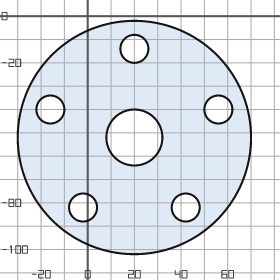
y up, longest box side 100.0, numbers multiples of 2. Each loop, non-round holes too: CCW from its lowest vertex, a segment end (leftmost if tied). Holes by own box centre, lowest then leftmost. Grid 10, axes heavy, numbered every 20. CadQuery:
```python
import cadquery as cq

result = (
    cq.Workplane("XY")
    .moveTo(20.0, -52.0)
    .circle(50.0)
    .moveTo(-2.0, -82.0)
    .circle(6.0)
    .moveTo(42.0, -82.0)
    .circle(6.0)
    .moveTo(20.0, -52.0)
    .circle(12.0)
    .moveTo(-16.0, -40.0)
    .circle(6.0)
    .moveTo(56.0, -40.0)
    .circle(6.0)
    .moveTo(20.0, -14.0)
    .circle(6.0)
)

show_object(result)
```